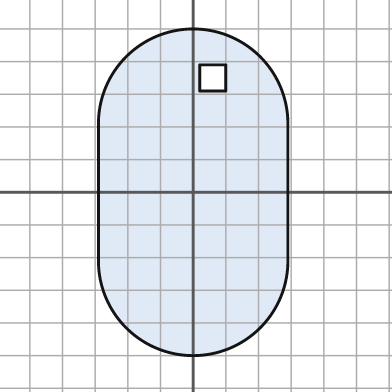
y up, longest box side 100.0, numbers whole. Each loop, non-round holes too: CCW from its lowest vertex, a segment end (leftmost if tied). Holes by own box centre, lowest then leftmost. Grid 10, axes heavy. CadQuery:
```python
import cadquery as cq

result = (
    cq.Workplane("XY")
    .moveTo(-29.0, -21.0)
    .threePointArc((0.0, -50.0), (29.0, -21.0))
    .lineTo(29.0, 21.0)
    .threePointArc((0.0, 50.0), (-29.0, 21.0))
    .close()
    .moveTo(2.0, 31.0)
    .lineTo(10.0, 31.0)
    .lineTo(10.0, 39.0)
    .lineTo(2.0, 39.0)
    .close()
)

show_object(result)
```